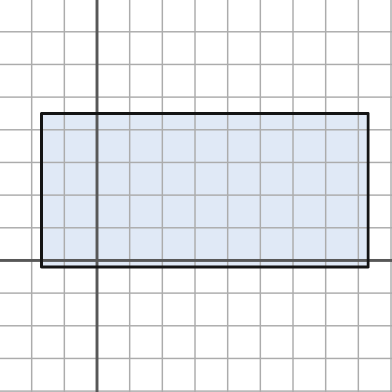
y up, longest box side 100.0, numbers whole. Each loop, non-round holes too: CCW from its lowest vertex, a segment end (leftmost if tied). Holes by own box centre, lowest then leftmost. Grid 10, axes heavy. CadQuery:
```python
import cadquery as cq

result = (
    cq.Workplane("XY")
    .moveTo(-17.0, -2.0)
    .lineTo(83.0, -2.0)
    .lineTo(83.0, 45.0)
    .lineTo(-17.0, 45.0)
    .close()
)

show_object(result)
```